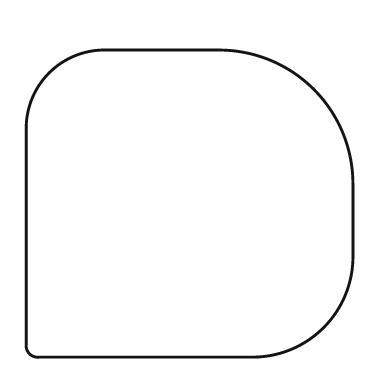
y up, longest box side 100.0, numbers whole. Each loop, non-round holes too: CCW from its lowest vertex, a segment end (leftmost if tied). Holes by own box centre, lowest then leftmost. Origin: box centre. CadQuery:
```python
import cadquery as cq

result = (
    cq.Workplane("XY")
    .moveTo(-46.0, -47.0)
    .lineTo(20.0, -47.0)
    .threePointArc((41.0, -38.0), (50.0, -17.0))
    .lineTo(50.0, 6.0)
    .threePointArc((38.0, 35.0), (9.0, 47.0))
    .lineTo(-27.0, 47.0)
    .threePointArc((-43.0, 40.0), (-50.0, 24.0))
    .lineTo(-50.0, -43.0)
    .threePointArc((-49.0, -46.0), (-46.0, -47.0))
    .close()
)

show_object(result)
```